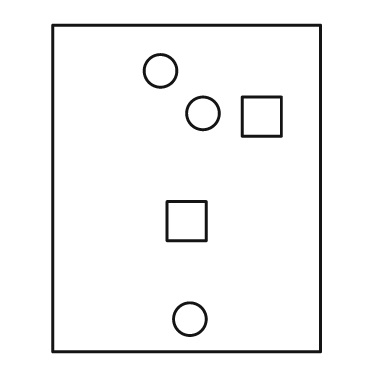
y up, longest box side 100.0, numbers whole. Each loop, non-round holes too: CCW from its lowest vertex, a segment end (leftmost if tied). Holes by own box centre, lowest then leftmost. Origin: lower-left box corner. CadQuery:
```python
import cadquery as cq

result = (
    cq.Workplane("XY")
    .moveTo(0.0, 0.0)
    .lineTo(82.0, 0.0)
    .lineTo(82.0, 100.0)
    .lineTo(0.0, 100.0)
    .close()
    .moveTo(42.0, 10.0)
    .circle(5.0)
    .moveTo(35.0, 34.0)
    .lineTo(47.0, 34.0)
    .lineTo(47.0, 46.0)
    .lineTo(35.0, 46.0)
    .close()
    .moveTo(58.0, 66.0)
    .lineTo(70.0, 66.0)
    .lineTo(70.0, 78.0)
    .lineTo(58.0, 78.0)
    .close()
    .moveTo(46.0, 73.0)
    .circle(5.0)
    .moveTo(33.0, 86.0)
    .circle(5.0)
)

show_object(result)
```